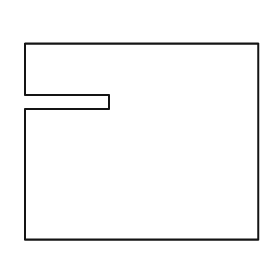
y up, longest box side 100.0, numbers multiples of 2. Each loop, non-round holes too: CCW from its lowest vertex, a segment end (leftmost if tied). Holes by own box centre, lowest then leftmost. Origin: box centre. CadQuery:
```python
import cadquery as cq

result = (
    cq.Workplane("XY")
    .moveTo(-50.0, -42.0)
    .lineTo(50.0, -42.0)
    .lineTo(50.0, 42.0)
    .lineTo(-50.0, 42.0)
    .lineTo(-50.0, 20.0)
    .lineTo(-14.0, 20.0)
    .lineTo(-14.0, 14.0)
    .lineTo(-50.0, 14.0)
    .close()
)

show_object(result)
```